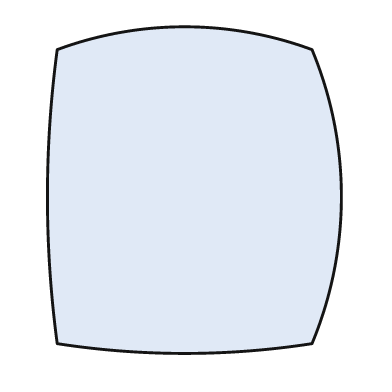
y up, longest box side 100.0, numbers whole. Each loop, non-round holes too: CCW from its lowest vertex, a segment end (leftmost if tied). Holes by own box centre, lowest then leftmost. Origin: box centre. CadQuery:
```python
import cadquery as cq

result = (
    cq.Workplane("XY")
    .moveTo(-42.0, -47.0)
    .threePointArc((-3.0, -50.0), (36.0, -47.0))
    .threePointArc((45.0, -2.0), (36.0, 43.0))
    .threePointArc((-3.0, 50.0), (-42.0, 43.0))
    .threePointArc((-45.0, -2.0), (-42.0, -47.0))
    .close()
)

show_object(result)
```